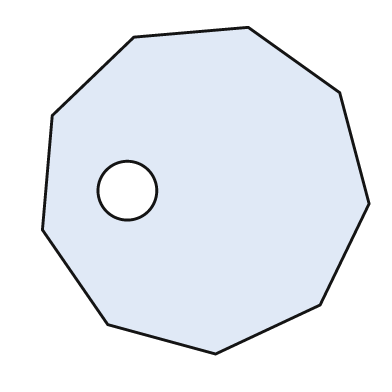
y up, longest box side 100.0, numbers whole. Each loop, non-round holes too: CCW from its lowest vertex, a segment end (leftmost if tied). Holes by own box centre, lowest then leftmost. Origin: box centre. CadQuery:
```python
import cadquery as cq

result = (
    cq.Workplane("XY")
    .moveTo(3.0, -50.0)
    .lineTo(35.0, -35.0)
    .lineTo(50.0, -4.0)
    .lineTo(41.0, 30.0)
    .lineTo(13.0, 50.0)
    .lineTo(-22.0, 47.0)
    .lineTo(-47.0, 23.0)
    .lineTo(-50.0, -12.0)
    .lineTo(-30.0, -41.0)
    .close()
    .moveTo(-24.0, 0.0)
    .circle(9.0)
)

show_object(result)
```